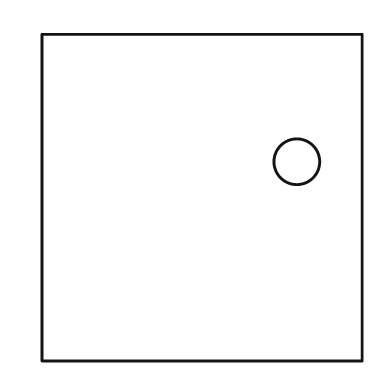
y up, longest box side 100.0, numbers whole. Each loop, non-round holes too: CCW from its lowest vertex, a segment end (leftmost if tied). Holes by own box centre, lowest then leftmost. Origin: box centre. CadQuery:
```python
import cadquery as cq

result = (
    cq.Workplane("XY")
    .moveTo(-49.0, -50.0)
    .lineTo(49.0, -50.0)
    .lineTo(49.0, 50.0)
    .lineTo(-49.0, 50.0)
    .close()
    .moveTo(29.0, 11.0)
    .circle(7.0)
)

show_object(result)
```